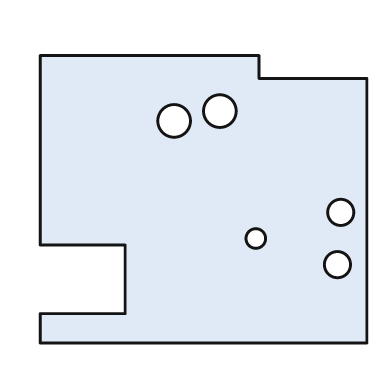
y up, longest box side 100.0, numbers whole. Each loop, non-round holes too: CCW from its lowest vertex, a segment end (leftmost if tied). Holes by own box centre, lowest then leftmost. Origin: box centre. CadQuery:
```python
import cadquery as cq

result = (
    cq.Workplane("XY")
    .moveTo(-50.0, -44.0)
    .lineTo(50.0, -44.0)
    .lineTo(50.0, 37.0)
    .lineTo(17.0, 37.0)
    .lineTo(17.0, 44.0)
    .lineTo(-50.0, 44.0)
    .lineTo(-50.0, -14.0)
    .lineTo(-24.0, -14.0)
    .lineTo(-24.0, -35.0)
    .lineTo(-50.0, -35.0)
    .close()
    .moveTo(41.0, -20.0)
    .circle(4.0)
    .moveTo(16.0, -12.0)
    .circle(3.0)
    .moveTo(42.0, -4.0)
    .circle(4.0)
    .moveTo(-9.0, 24.0)
    .circle(5.0)
    .moveTo(5.0, 27.0)
    .circle(5.0)
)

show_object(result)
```